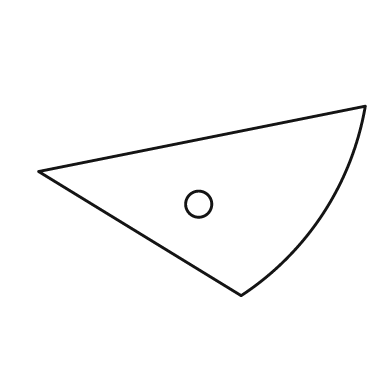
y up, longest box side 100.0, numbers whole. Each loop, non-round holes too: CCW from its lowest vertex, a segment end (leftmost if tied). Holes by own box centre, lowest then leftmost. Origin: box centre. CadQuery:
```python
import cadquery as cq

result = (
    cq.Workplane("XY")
    .moveTo(12.0, -29.0)
    .threePointArc((37.0, -4.0), (50.0, 29.0))
    .lineTo(-50.0, 9.0)
    .close()
    .moveTo(-1.0, -1.0)
    .circle(4.0)
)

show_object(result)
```